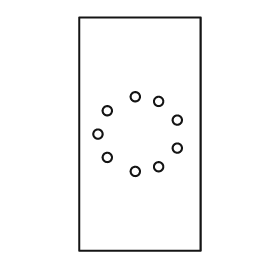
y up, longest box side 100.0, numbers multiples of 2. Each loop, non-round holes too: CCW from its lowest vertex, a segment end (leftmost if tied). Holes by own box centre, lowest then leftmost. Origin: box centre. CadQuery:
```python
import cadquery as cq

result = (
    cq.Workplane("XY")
    .moveTo(-26.0, -50.0)
    .lineTo(26.0, -50.0)
    .lineTo(26.0, 50.0)
    .lineTo(-26.0, 50.0)
    .close()
    .moveTo(-2.0, -16.0)
    .circle(2.0)
    .moveTo(8.0, -14.0)
    .circle(2.0)
    .moveTo(-14.0, -10.0)
    .circle(2.0)
    .moveTo(16.0, -6.0)
    .circle(2.0)
    .moveTo(-18.0, 0.0)
    .circle(2.0)
    .moveTo(16.0, 6.0)
    .circle(2.0)
    .moveTo(-14.0, 10.0)
    .circle(2.0)
    .moveTo(8.0, 14.0)
    .circle(2.0)
    .moveTo(-2.0, 16.0)
    .circle(2.0)
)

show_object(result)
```